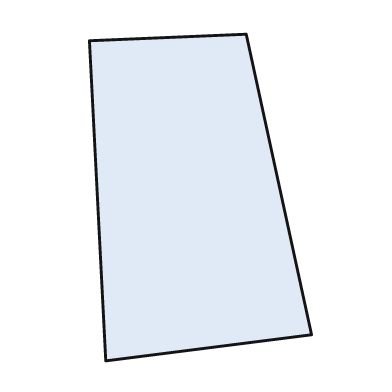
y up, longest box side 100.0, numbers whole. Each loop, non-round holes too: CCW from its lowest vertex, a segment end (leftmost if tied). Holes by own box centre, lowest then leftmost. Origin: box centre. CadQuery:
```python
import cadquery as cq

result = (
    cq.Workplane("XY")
    .moveTo(-29.0, -50.0)
    .lineTo(34.0, -42.0)
    .lineTo(14.0, 50.0)
    .lineTo(-34.0, 48.0)
    .close()
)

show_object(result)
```